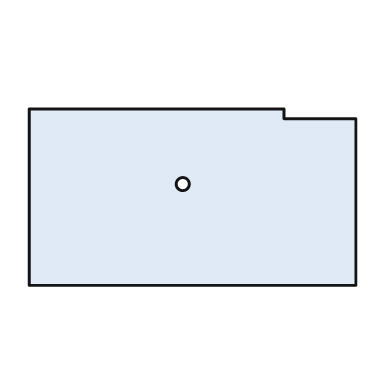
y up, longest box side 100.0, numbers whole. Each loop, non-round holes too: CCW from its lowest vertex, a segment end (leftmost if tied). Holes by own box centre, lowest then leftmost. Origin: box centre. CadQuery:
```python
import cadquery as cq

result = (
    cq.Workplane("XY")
    .moveTo(-50.0, -27.0)
    .lineTo(50.0, -27.0)
    .lineTo(50.0, 24.0)
    .lineTo(28.0, 24.0)
    .lineTo(28.0, 27.0)
    .lineTo(-50.0, 27.0)
    .close()
    .moveTo(-3.0, 4.0)
    .circle(2.0)
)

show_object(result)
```